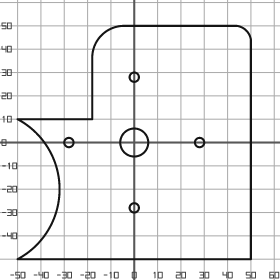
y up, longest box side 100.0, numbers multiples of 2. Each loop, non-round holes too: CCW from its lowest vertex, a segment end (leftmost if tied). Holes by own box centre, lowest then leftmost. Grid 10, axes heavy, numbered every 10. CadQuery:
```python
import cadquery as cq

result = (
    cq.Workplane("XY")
    .moveTo(-50.0, -50.0)
    .lineTo(50.0, -50.0)
    .lineTo(50.0, 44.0)
    .threePointArc((48.0, 48.0), (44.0, 50.0))
    .lineTo(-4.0, 50.0)
    .threePointArc((-14.0, 46.0), (-18.0, 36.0))
    .lineTo(-18.0, 10.0)
    .lineTo(-50.0, 10.0)
    .threePointArc((-32.0, -20.0), (-50.0, -50.0))
    .close()
    .moveTo(0.0, -28.0)
    .circle(2.0)
    .moveTo(-28.0, 0.0)
    .circle(2.0)
    .moveTo(0.0, 0.0)
    .circle(6.0)
    .moveTo(28.0, 0.0)
    .circle(2.0)
    .moveTo(0.0, 28.0)
    .circle(2.0)
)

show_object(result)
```